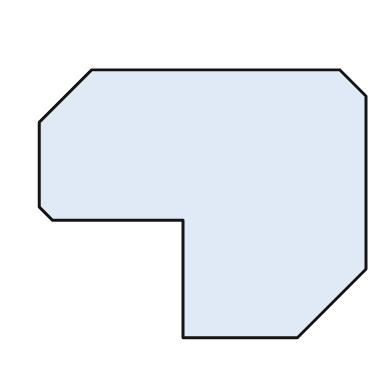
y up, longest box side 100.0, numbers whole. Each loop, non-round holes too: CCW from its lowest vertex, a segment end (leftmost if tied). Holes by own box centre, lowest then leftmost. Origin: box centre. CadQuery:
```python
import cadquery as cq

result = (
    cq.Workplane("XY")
    .moveTo(-6.0, -41.0)
    .lineTo(29.0, -41.0)
    .lineTo(50.0, -20.0)
    .lineTo(50.0, 33.0)
    .lineTo(42.0, 41.0)
    .lineTo(-34.0, 41.0)
    .lineTo(-50.0, 25.0)
    .lineTo(-50.0, -1.0)
    .lineTo(-46.0, -5.0)
    .lineTo(-6.0, -5.0)
    .close()
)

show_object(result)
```